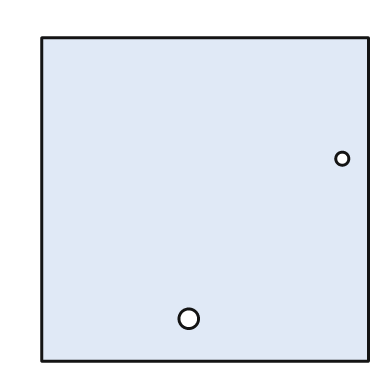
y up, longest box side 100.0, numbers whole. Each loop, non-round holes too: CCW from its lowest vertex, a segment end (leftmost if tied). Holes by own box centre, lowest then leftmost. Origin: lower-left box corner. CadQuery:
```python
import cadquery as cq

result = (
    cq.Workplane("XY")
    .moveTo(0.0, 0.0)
    .lineTo(100.0, 0.0)
    .lineTo(100.0, 99.0)
    .lineTo(0.0, 99.0)
    .close()
    .moveTo(45.0, 13.0)
    .circle(3.0)
    .moveTo(92.0, 62.0)
    .circle(2.0)
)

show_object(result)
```